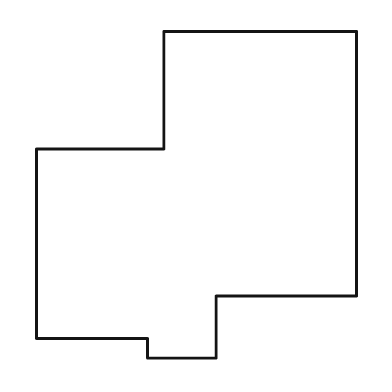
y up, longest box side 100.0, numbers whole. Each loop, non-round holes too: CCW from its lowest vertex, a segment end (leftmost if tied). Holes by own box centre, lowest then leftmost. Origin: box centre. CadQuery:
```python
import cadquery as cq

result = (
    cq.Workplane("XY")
    .moveTo(-15.0, -50.0)
    .lineTo(6.0, -50.0)
    .lineTo(6.0, -31.0)
    .lineTo(49.0, -31.0)
    .lineTo(49.0, 50.0)
    .lineTo(-10.0, 50.0)
    .lineTo(-10.0, 14.0)
    .lineTo(-49.0, 14.0)
    .lineTo(-49.0, -44.0)
    .lineTo(-15.0, -44.0)
    .close()
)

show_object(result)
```